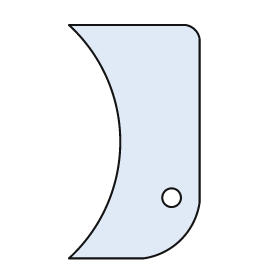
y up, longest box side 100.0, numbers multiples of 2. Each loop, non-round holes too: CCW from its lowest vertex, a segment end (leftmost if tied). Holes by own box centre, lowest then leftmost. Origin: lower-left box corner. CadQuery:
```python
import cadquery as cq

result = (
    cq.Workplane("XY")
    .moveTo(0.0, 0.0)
    .lineTo(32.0, 0.0)
    .threePointArc((48.0, 8.0), (56.0, 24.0))
    .lineTo(56.0, 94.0)
    .threePointArc((54.0, 98.0), (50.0, 100.0))
    .lineTo(0.0, 100.0)
    .threePointArc((22.0, 50.0), (0.0, 0.0))
    .close()
    .moveTo(44.0, 26.0)
    .circle(4.0)
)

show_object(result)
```